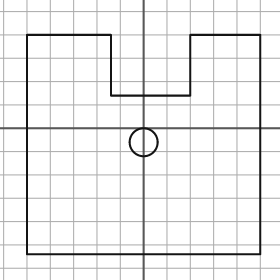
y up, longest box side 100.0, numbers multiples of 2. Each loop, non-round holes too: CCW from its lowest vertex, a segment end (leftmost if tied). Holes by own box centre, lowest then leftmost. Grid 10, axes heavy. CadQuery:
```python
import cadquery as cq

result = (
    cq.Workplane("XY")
    .moveTo(-50.0, -54.0)
    .lineTo(50.0, -54.0)
    .lineTo(50.0, 40.0)
    .lineTo(20.0, 40.0)
    .lineTo(20.0, 14.0)
    .lineTo(-14.0, 14.0)
    .lineTo(-14.0, 40.0)
    .lineTo(-50.0, 40.0)
    .close()
    .moveTo(0.0, -6.0)
    .circle(6.0)
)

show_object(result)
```